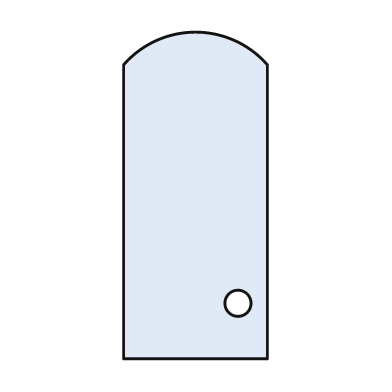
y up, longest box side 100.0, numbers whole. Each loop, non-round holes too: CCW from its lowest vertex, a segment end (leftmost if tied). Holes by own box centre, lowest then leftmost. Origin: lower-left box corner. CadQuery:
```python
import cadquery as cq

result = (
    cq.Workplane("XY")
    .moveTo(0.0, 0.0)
    .lineTo(44.0, 0.0)
    .lineTo(44.0, 90.0)
    .threePointArc((22.0, 100.0), (0.0, 90.0))
    .close()
    .moveTo(35.0, 17.0)
    .circle(4.0)
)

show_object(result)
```